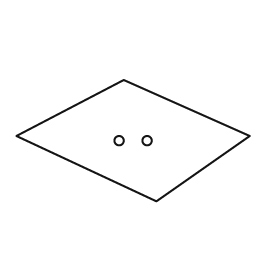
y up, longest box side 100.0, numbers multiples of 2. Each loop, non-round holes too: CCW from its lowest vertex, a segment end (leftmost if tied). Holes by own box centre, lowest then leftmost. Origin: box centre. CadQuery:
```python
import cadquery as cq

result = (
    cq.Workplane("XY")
    .moveTo(10.0, -26.0)
    .lineTo(50.0, 2.0)
    .lineTo(-4.0, 26.0)
    .lineTo(-50.0, 2.0)
    .close()
    .moveTo(-6.0, 0.0)
    .circle(2.0)
    .moveTo(6.0, 0.0)
    .circle(2.0)
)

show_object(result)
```